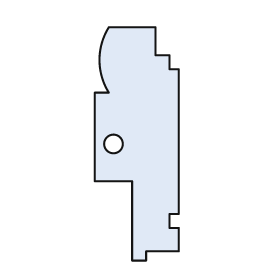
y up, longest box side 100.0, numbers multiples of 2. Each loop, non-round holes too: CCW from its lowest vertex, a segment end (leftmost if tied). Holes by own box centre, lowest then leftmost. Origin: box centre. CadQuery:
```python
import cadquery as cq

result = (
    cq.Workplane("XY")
    .moveTo(-2.0, -50.0)
    .lineTo(4.0, -50.0)
    .lineTo(4.0, -46.0)
    .lineTo(18.0, -46.0)
    .lineTo(18.0, -36.0)
    .lineTo(14.0, -36.0)
    .lineTo(14.0, -30.0)
    .lineTo(18.0, -30.0)
    .lineTo(18.0, 32.0)
    .lineTo(14.0, 32.0)
    .lineTo(14.0, 38.0)
    .lineTo(8.0, 38.0)
    .lineTo(8.0, 50.0)
    .lineTo(-12.0, 50.0)
    .threePointArc((-16.0, 36.0), (-12.0, 22.0))
    .lineTo(-18.0, 22.0)
    .lineTo(-18.0, -16.0)
    .lineTo(-2.0, -16.0)
    .close()
    .moveTo(-10.0, 0.0)
    .circle(4.0)
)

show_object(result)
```